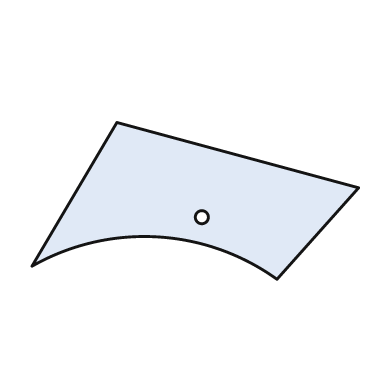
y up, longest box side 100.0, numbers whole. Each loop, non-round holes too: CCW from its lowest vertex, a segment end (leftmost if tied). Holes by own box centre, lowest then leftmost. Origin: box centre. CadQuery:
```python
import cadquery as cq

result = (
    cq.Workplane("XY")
    .moveTo(25.0, -24.0)
    .lineTo(50.0, 4.0)
    .lineTo(-24.0, 24.0)
    .lineTo(-50.0, -20.0)
    .threePointArc((-12.0, -11.0), (25.0, -24.0))
    .close()
    .moveTo(2.0, -5.0)
    .circle(2.0)
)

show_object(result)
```